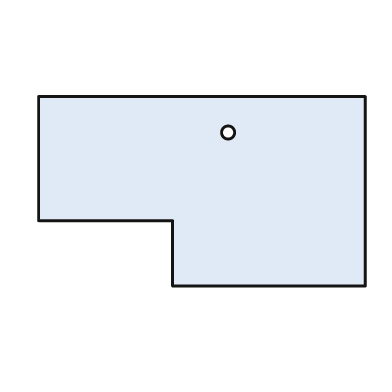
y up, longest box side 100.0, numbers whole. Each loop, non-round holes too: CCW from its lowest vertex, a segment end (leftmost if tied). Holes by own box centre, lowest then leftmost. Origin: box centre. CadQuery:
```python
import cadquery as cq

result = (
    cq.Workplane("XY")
    .moveTo(-9.0, -29.0)
    .lineTo(50.0, -29.0)
    .lineTo(50.0, 29.0)
    .lineTo(-50.0, 29.0)
    .lineTo(-50.0, -9.0)
    .lineTo(-9.0, -9.0)
    .close()
    .moveTo(8.0, 18.0)
    .circle(2.0)
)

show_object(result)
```